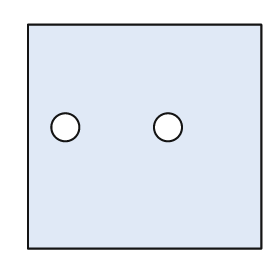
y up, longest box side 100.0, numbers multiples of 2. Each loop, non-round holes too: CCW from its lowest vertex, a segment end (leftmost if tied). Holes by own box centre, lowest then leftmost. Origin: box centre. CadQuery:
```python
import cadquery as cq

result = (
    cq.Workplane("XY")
    .moveTo(-50.0, -48.0)
    .lineTo(50.0, -48.0)
    .lineTo(50.0, 48.0)
    .lineTo(-50.0, 48.0)
    .close()
    .moveTo(-34.0, 4.0)
    .circle(6.0)
    .moveTo(10.0, 4.0)
    .circle(6.0)
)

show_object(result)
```